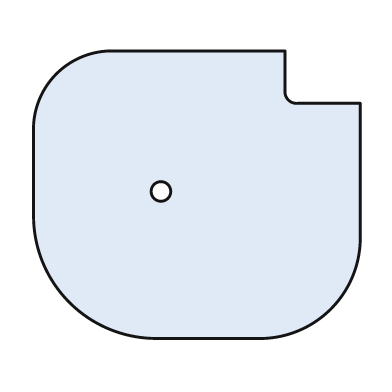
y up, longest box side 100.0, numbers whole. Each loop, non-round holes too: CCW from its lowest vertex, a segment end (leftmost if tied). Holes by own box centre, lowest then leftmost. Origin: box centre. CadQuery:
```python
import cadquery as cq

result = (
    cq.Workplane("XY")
    .moveTo(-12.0, -44.0)
    .lineTo(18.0, -44.0)
    .threePointArc((41.0, -35.0), (50.0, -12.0))
    .lineTo(50.0, 28.0)
    .lineTo(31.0, 28.0)
    .threePointArc((28.0, 29.0), (27.0, 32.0))
    .lineTo(27.0, 44.0)
    .lineTo(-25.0, 44.0)
    .threePointArc((-43.0, 37.0), (-50.0, 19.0))
    .lineTo(-50.0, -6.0)
    .threePointArc((-39.0, -33.0), (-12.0, -44.0))
    .close()
    .moveTo(-11.0, 1.0)
    .circle(3.0)
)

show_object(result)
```